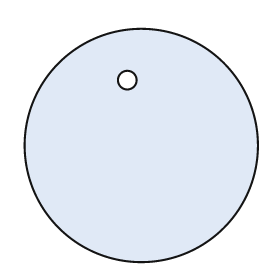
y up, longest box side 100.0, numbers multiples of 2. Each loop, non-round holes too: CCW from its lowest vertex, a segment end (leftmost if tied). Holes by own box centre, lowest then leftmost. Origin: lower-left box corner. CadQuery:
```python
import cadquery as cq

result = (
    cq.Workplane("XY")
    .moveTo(50.0, 50.0)
    .circle(50.0)
    .moveTo(44.0, 78.0)
    .circle(4.0)
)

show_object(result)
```